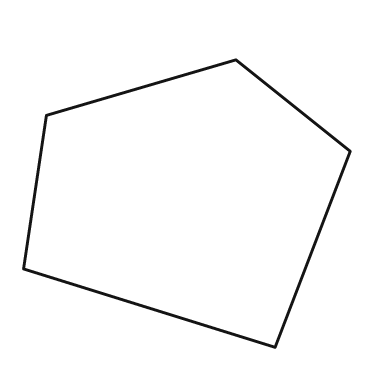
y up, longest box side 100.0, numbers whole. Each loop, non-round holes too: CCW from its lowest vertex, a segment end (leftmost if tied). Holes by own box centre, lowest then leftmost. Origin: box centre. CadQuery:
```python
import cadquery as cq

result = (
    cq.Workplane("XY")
    .moveTo(27.0, -44.0)
    .lineTo(50.0, 16.0)
    .lineTo(15.0, 44.0)
    .lineTo(-43.0, 27.0)
    .lineTo(-50.0, -20.0)
    .close()
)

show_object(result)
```